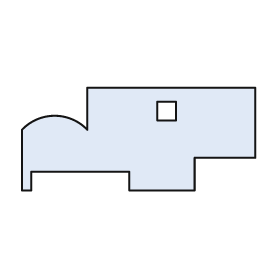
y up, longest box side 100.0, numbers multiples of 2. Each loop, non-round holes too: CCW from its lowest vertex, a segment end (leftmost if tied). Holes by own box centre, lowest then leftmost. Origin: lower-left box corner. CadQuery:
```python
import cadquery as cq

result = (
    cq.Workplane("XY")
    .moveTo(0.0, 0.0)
    .lineTo(4.0, 0.0)
    .lineTo(4.0, 8.0)
    .lineTo(46.0, 8.0)
    .lineTo(46.0, 0.0)
    .lineTo(74.0, 0.0)
    .lineTo(74.0, 14.0)
    .lineTo(100.0, 14.0)
    .lineTo(100.0, 44.0)
    .lineTo(28.0, 44.0)
    .lineTo(28.0, 26.0)
    .threePointArc((14.0, 32.0), (0.0, 26.0))
    .close()
    .moveTo(58.0, 30.0)
    .lineTo(66.0, 30.0)
    .lineTo(66.0, 38.0)
    .lineTo(58.0, 38.0)
    .close()
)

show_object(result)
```